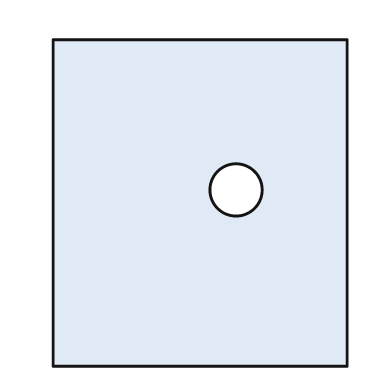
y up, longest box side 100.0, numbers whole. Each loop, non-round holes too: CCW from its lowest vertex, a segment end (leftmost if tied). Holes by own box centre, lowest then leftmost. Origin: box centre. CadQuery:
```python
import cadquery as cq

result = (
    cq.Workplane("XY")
    .moveTo(-45.0, -50.0)
    .lineTo(45.0, -50.0)
    .lineTo(45.0, 50.0)
    .lineTo(-45.0, 50.0)
    .close()
    .moveTo(11.0, 4.0)
    .circle(8.0)
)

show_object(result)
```